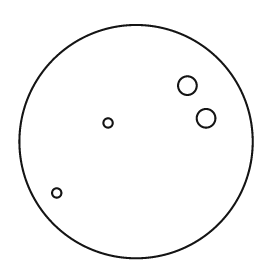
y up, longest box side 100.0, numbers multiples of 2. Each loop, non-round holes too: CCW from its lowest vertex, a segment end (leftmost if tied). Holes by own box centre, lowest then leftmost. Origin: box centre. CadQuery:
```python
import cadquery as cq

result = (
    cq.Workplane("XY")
    .moveTo(0.0, 0.0)
    .circle(50.0)
    .moveTo(-34.0, -22.0)
    .circle(2.0)
    .moveTo(-12.0, 8.0)
    .circle(2.0)
    .moveTo(30.0, 10.0)
    .circle(4.0)
    .moveTo(22.0, 24.0)
    .circle(4.0)
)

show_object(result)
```